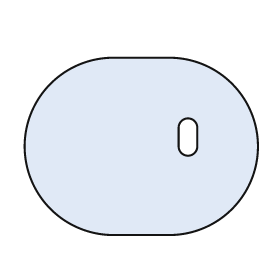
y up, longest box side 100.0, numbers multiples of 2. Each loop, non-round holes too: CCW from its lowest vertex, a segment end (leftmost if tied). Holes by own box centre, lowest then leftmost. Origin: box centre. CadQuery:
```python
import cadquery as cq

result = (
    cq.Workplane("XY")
    .moveTo(-12.0, -38.0)
    .lineTo(12.0, -38.0)
    .threePointArc((50.0, 0.0), (12.0, 38.0))
    .lineTo(-12.0, 38.0)
    .threePointArc((-50.0, 0.0), (-12.0, -38.0))
    .close()
    .moveTo(16.0, 0.0)
    .threePointArc((20.0, -4.0), (24.0, 0.0))
    .lineTo(24.0, 8.0)
    .threePointArc((20.0, 12.0), (16.0, 8.0))
    .close()
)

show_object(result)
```